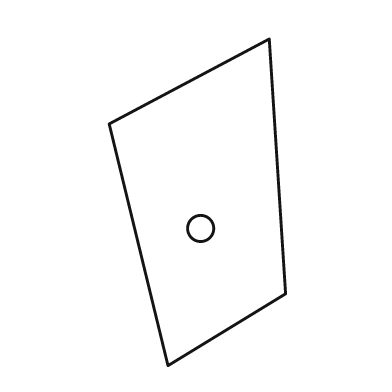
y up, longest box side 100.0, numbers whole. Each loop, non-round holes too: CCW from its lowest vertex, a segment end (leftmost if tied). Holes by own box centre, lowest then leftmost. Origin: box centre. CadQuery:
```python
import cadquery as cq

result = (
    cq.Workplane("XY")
    .moveTo(-9.0, -50.0)
    .lineTo(27.0, -28.0)
    .lineTo(22.0, 50.0)
    .lineTo(-27.0, 24.0)
    .close()
    .moveTo(1.0, -8.0)
    .circle(4.0)
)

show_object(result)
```